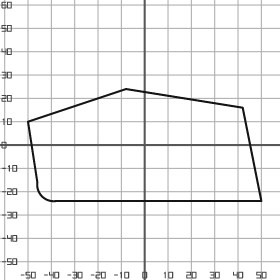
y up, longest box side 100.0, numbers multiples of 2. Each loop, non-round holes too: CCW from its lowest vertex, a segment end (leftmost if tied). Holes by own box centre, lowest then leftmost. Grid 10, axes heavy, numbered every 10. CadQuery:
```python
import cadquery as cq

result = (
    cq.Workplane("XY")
    .moveTo(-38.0, -24.0)
    .lineTo(50.0, -24.0)
    .lineTo(42.0, 16.0)
    .lineTo(-8.0, 24.0)
    .lineTo(-50.0, 10.0)
    .lineTo(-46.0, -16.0)
    .threePointArc((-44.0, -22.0), (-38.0, -24.0))
    .close()
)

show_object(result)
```